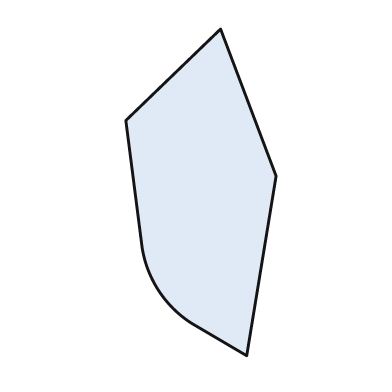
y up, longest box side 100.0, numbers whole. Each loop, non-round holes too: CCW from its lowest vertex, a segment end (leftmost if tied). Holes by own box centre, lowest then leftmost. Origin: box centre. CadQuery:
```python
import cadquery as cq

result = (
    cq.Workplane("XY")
    .moveTo(14.0, -50.0)
    .lineTo(23.0, 5.0)
    .lineTo(6.0, 50.0)
    .lineTo(-23.0, 22.0)
    .lineTo(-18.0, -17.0)
    .threePointArc((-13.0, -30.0), (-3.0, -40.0))
    .close()
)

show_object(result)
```